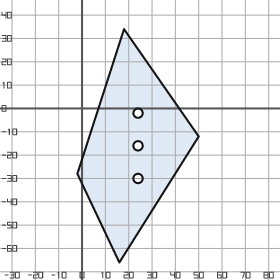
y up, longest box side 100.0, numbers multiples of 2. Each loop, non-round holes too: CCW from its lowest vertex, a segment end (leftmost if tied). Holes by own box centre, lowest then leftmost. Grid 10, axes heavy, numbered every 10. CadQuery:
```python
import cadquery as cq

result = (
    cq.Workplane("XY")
    .moveTo(16.0, -66.0)
    .lineTo(50.0, -12.0)
    .lineTo(18.0, 34.0)
    .lineTo(-2.0, -28.0)
    .close()
    .moveTo(24.0, -30.0)
    .circle(2.0)
    .moveTo(24.0, -16.0)
    .circle(2.0)
    .moveTo(24.0, -2.0)
    .circle(2.0)
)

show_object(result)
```